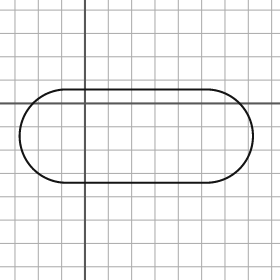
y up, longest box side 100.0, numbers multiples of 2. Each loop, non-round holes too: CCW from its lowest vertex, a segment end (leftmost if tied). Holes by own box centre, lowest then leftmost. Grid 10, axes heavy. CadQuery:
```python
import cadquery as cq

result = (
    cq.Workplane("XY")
    .moveTo(-8.0, -34.0)
    .lineTo(52.0, -34.0)
    .threePointArc((72.0, -14.0), (52.0, 6.0))
    .lineTo(-8.0, 6.0)
    .threePointArc((-28.0, -14.0), (-8.0, -34.0))
    .close()
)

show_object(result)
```